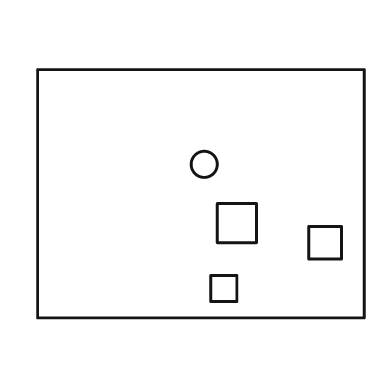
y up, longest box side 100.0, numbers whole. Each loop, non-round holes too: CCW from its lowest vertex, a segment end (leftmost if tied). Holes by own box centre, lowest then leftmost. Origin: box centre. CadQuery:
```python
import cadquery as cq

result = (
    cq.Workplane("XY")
    .moveTo(-50.0, -38.0)
    .lineTo(50.0, -38.0)
    .lineTo(50.0, 38.0)
    .lineTo(-50.0, 38.0)
    .close()
    .moveTo(3.0, -33.0)
    .lineTo(11.0, -33.0)
    .lineTo(11.0, -25.0)
    .lineTo(3.0, -25.0)
    .close()
    .moveTo(33.0, -20.0)
    .lineTo(43.0, -20.0)
    .lineTo(43.0, -10.0)
    .lineTo(33.0, -10.0)
    .close()
    .moveTo(5.0, -15.0)
    .lineTo(17.0, -15.0)
    .lineTo(17.0, -3.0)
    .lineTo(5.0, -3.0)
    .close()
    .moveTo(1.0, 9.0)
    .circle(4.0)
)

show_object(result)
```